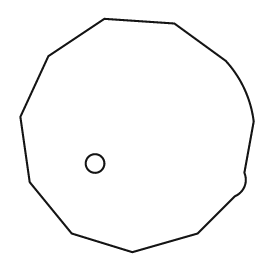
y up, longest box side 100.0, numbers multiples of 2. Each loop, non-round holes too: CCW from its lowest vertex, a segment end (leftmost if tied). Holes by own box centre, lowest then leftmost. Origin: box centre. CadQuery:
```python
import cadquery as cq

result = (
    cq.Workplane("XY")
    .moveTo(-2.0, -50.0)
    .lineTo(26.0, -42.0)
    .lineTo(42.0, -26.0)
    .threePointArc((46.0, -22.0), (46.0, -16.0))
    .lineTo(50.0, 6.0)
    .threePointArc((46.0, 20.0), (38.0, 32.0))
    .lineTo(16.0, 48.0)
    .lineTo(-14.0, 50.0)
    .lineTo(-38.0, 34.0)
    .lineTo(-50.0, 8.0)
    .lineTo(-46.0, -20.0)
    .lineTo(-28.0, -42.0)
    .close()
    .moveTo(-18.0, -12.0)
    .circle(4.0)
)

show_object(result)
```